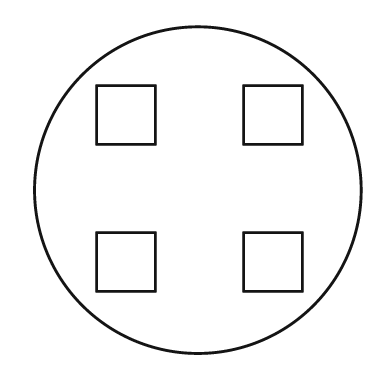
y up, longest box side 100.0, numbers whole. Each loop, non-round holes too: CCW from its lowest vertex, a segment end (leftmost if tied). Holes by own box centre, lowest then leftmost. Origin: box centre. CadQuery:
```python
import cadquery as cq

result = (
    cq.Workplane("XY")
    .moveTo(0.0, 0.0)
    .circle(50.0)
    .moveTo(-31.0, -31.0)
    .lineTo(-13.0, -31.0)
    .lineTo(-13.0, -13.0)
    .lineTo(-31.0, -13.0)
    .close()
    .moveTo(14.0, -31.0)
    .lineTo(32.0, -31.0)
    .lineTo(32.0, -13.0)
    .lineTo(14.0, -13.0)
    .close()
    .moveTo(-31.0, 14.0)
    .lineTo(-13.0, 14.0)
    .lineTo(-13.0, 32.0)
    .lineTo(-31.0, 32.0)
    .close()
    .moveTo(14.0, 14.0)
    .lineTo(32.0, 14.0)
    .lineTo(32.0, 32.0)
    .lineTo(14.0, 32.0)
    .close()
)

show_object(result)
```